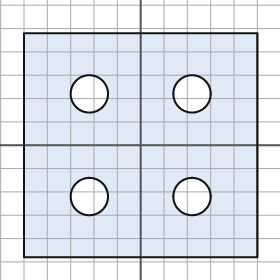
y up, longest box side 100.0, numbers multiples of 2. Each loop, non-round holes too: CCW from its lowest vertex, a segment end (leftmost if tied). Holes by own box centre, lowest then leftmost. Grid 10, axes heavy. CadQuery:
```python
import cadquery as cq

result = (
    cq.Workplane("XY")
    .moveTo(-50.0, -48.0)
    .lineTo(50.0, -48.0)
    .lineTo(50.0, 48.0)
    .lineTo(-50.0, 48.0)
    .close()
    .moveTo(-22.0, -22.0)
    .circle(8.0)
    .moveTo(22.0, -22.0)
    .circle(8.0)
    .moveTo(-22.0, 22.0)
    .circle(8.0)
    .moveTo(22.0, 22.0)
    .circle(8.0)
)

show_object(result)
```